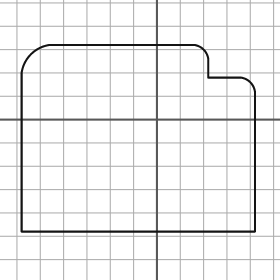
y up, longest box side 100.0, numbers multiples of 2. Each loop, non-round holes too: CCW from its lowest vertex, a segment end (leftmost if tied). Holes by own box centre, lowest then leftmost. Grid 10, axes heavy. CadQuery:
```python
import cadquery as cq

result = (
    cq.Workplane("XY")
    .moveTo(-58.0, -48.0)
    .lineTo(42.0, -48.0)
    .lineTo(42.0, 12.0)
    .threePointArc((40.0, 16.0), (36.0, 18.0))
    .lineTo(22.0, 18.0)
    .lineTo(22.0, 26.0)
    .threePointArc((20.0, 30.0), (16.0, 32.0))
    .lineTo(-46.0, 32.0)
    .threePointArc((-54.0, 28.0), (-58.0, 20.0))
    .close()
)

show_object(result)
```